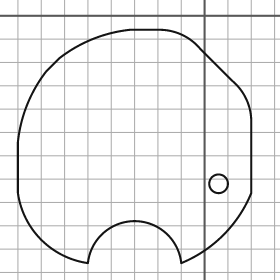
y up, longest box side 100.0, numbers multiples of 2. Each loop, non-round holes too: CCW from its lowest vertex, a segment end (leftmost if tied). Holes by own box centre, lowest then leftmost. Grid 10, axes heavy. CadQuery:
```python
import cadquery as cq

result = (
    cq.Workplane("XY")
    .moveTo(-50.0, -106.0)
    .threePointArc((-30.0, -88.0), (-10.0, -106.0))
    .threePointArc((8.0, -94.0), (20.0, -76.0))
    .lineTo(20.0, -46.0)
    .threePointArc((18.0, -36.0), (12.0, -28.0))
    .lineTo(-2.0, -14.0)
    .threePointArc((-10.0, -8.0), (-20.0, -6.0))
    .lineTo(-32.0, -6.0)
    .threePointArc((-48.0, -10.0), (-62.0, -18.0))
    .lineTo(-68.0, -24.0)
    .threePointArc((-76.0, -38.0), (-80.0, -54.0))
    .lineTo(-80.0, -76.0)
    .threePointArc((-70.0, -96.0), (-50.0, -106.0))
    .close()
    .moveTo(6.0, -72.0)
    .circle(4.0)
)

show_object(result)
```